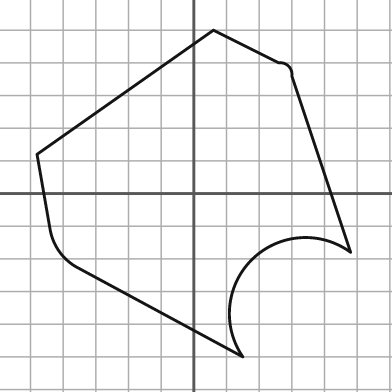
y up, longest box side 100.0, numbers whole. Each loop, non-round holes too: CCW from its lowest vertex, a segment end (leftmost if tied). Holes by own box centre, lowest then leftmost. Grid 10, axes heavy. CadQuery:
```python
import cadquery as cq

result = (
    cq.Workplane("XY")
    .moveTo(15.0, -50.0)
    .threePointArc((18.0, -20.0), (48.0, -18.0))
    .lineTo(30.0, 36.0)
    .threePointArc((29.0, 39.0), (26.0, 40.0))
    .lineTo(6.0, 50.0)
    .lineTo(-48.0, 12.0)
    .lineTo(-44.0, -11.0)
    .threePointArc((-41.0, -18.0), (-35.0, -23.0))
    .close()
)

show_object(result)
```